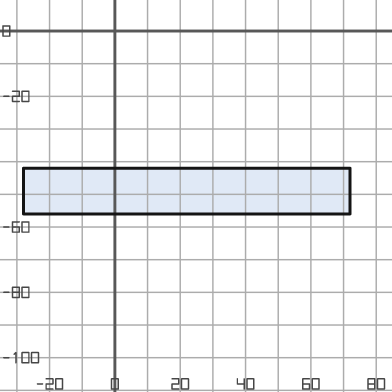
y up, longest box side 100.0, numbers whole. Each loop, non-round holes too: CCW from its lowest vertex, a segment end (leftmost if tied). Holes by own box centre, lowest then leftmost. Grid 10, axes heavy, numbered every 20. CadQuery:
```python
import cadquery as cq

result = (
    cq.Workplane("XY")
    .moveTo(-28.0, -56.0)
    .lineTo(72.0, -56.0)
    .lineTo(72.0, -42.0)
    .lineTo(-28.0, -42.0)
    .close()
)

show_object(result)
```